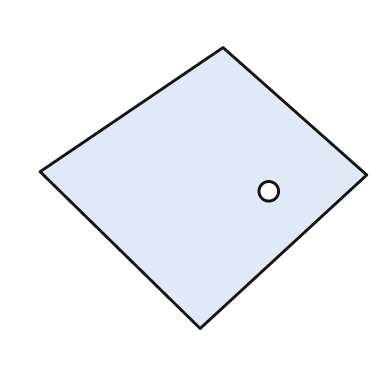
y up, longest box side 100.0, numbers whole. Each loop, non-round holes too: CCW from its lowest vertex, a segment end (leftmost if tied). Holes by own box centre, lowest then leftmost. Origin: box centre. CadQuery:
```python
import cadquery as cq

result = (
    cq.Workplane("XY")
    .moveTo(-1.0, -43.0)
    .lineTo(50.0, 4.0)
    .lineTo(6.0, 43.0)
    .lineTo(-50.0, 5.0)
    .close()
    .moveTo(20.0, -1.0)
    .circle(3.0)
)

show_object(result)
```